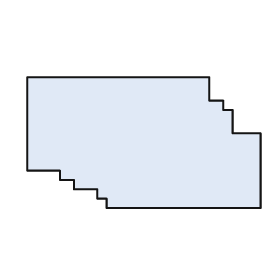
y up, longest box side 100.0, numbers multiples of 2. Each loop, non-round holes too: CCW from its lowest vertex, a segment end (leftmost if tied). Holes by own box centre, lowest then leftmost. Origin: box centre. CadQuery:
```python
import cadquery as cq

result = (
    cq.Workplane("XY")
    .moveTo(-16.0, -28.0)
    .lineTo(50.0, -28.0)
    .lineTo(50.0, 4.0)
    .lineTo(38.0, 4.0)
    .lineTo(38.0, 14.0)
    .lineTo(34.0, 14.0)
    .lineTo(34.0, 18.0)
    .lineTo(28.0, 18.0)
    .lineTo(28.0, 28.0)
    .lineTo(-50.0, 28.0)
    .lineTo(-50.0, -12.0)
    .lineTo(-36.0, -12.0)
    .lineTo(-36.0, -16.0)
    .lineTo(-30.0, -16.0)
    .lineTo(-30.0, -20.0)
    .lineTo(-20.0, -20.0)
    .lineTo(-20.0, -24.0)
    .lineTo(-16.0, -24.0)
    .close()
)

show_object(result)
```